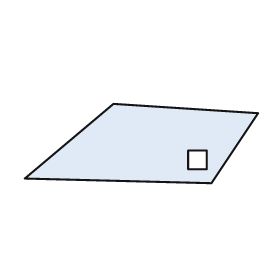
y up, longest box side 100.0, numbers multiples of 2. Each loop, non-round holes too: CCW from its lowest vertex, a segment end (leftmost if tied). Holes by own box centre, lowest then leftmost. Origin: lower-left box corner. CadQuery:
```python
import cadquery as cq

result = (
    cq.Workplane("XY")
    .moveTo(80.0, 0.0)
    .lineTo(100.0, 30.0)
    .lineTo(38.0, 34.0)
    .lineTo(0.0, 2.0)
    .close()
    .moveTo(70.0, 6.0)
    .lineTo(78.0, 6.0)
    .lineTo(78.0, 14.0)
    .lineTo(70.0, 14.0)
    .close()
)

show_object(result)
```